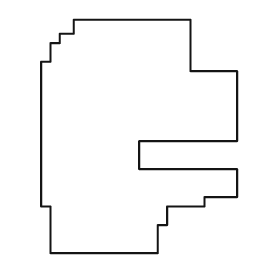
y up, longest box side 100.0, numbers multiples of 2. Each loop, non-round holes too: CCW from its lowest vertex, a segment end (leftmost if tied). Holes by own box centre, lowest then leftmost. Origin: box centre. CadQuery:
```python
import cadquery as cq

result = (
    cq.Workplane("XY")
    .moveTo(-38.0, -50.0)
    .lineTo(8.0, -50.0)
    .lineTo(8.0, -38.0)
    .lineTo(12.0, -38.0)
    .lineTo(12.0, -30.0)
    .lineTo(28.0, -30.0)
    .lineTo(28.0, -26.0)
    .lineTo(42.0, -26.0)
    .lineTo(42.0, -14.0)
    .lineTo(0.0, -14.0)
    .lineTo(0.0, -2.0)
    .lineTo(42.0, -2.0)
    .lineTo(42.0, 28.0)
    .lineTo(22.0, 28.0)
    .lineTo(22.0, 50.0)
    .lineTo(-28.0, 50.0)
    .lineTo(-28.0, 44.0)
    .lineTo(-34.0, 44.0)
    .lineTo(-34.0, 40.0)
    .lineTo(-38.0, 40.0)
    .lineTo(-38.0, 32.0)
    .lineTo(-42.0, 32.0)
    .lineTo(-42.0, -30.0)
    .lineTo(-38.0, -30.0)
    .close()
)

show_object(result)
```